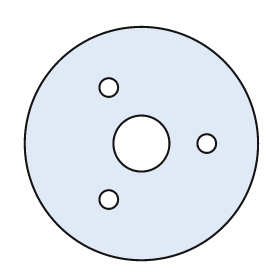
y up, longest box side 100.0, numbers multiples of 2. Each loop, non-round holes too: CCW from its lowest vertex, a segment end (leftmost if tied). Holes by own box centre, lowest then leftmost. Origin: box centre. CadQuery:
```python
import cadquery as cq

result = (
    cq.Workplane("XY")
    .moveTo(0.0, 0.0)
    .circle(50.0)
    .moveTo(-14.0, -24.0)
    .circle(4.0)
    .moveTo(0.0, 0.0)
    .circle(12.0)
    .moveTo(28.0, 0.0)
    .circle(4.0)
    .moveTo(-14.0, 24.0)
    .circle(4.0)
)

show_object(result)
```